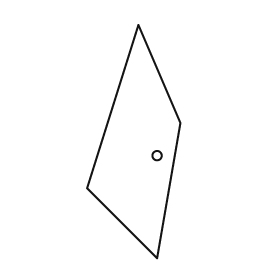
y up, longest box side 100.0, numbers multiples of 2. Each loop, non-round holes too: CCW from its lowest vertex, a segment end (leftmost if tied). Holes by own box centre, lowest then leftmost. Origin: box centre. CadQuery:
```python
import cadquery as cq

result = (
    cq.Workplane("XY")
    .moveTo(10.0, -50.0)
    .lineTo(20.0, 8.0)
    .lineTo(2.0, 50.0)
    .lineTo(-20.0, -20.0)
    .close()
    .moveTo(10.0, -6.0)
    .circle(2.0)
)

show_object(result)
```